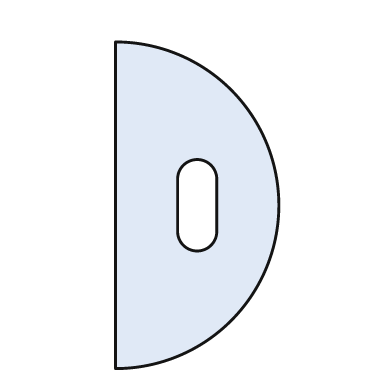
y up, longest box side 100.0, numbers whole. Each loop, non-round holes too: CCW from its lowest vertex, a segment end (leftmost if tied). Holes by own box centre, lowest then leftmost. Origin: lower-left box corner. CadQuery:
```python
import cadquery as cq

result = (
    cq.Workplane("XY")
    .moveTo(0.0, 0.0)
    .threePointArc((50.0, 50.0), (0.0, 100.0))
    .close()
    .moveTo(19.0, 42.0)
    .threePointArc((25.0, 36.0), (31.0, 42.0))
    .lineTo(31.0, 58.0)
    .threePointArc((25.0, 64.0), (19.0, 58.0))
    .close()
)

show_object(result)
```